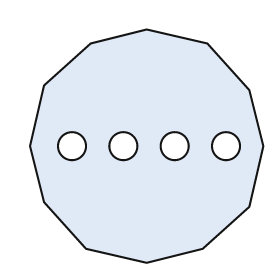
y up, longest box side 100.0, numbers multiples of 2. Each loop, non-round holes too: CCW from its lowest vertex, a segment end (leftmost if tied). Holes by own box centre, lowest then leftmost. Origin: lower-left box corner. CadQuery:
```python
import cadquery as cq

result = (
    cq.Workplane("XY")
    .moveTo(50.0, 0.0)
    .lineTo(74.0, 6.0)
    .lineTo(94.0, 24.0)
    .lineTo(100.0, 50.0)
    .lineTo(94.0, 74.0)
    .lineTo(76.0, 94.0)
    .lineTo(50.0, 100.0)
    .lineTo(26.0, 94.0)
    .lineTo(6.0, 76.0)
    .lineTo(0.0, 50.0)
    .lineTo(6.0, 26.0)
    .lineTo(24.0, 6.0)
    .close()
    .moveTo(18.0, 50.0)
    .circle(6.0)
    .moveTo(40.0, 50.0)
    .circle(6.0)
    .moveTo(62.0, 50.0)
    .circle(6.0)
    .moveTo(84.0, 50.0)
    .circle(6.0)
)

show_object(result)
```